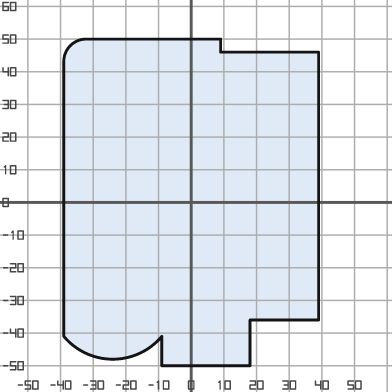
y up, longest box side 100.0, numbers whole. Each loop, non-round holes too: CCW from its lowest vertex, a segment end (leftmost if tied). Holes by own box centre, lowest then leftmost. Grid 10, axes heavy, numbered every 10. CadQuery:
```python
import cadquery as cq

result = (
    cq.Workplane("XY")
    .moveTo(-9.0, -50.0)
    .lineTo(18.0, -50.0)
    .lineTo(18.0, -36.0)
    .lineTo(39.0, -36.0)
    .lineTo(39.0, 46.0)
    .lineTo(9.0, 46.0)
    .lineTo(9.0, 50.0)
    .lineTo(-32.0, 50.0)
    .threePointArc((-37.0, 48.0), (-39.0, 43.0))
    .lineTo(-39.0, -41.0)
    .threePointArc((-24.0, -48.0), (-9.0, -41.0))
    .close()
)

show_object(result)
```